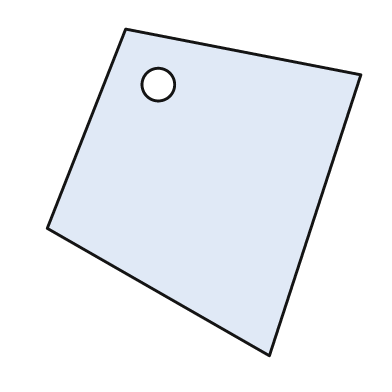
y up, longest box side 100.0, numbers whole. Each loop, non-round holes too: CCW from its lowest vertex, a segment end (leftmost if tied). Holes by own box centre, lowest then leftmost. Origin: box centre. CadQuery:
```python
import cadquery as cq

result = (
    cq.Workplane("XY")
    .moveTo(20.0, -50.0)
    .lineTo(48.0, 36.0)
    .lineTo(-24.0, 50.0)
    .lineTo(-48.0, -11.0)
    .close()
    .moveTo(-14.0, 33.0)
    .circle(5.0)
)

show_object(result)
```